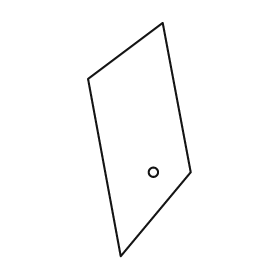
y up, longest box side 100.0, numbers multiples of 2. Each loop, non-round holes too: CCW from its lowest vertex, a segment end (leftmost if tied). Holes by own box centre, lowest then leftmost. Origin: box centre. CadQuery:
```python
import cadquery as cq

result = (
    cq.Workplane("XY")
    .moveTo(-8.0, -50.0)
    .lineTo(22.0, -14.0)
    .lineTo(10.0, 50.0)
    .lineTo(-22.0, 26.0)
    .close()
    .moveTo(6.0, -14.0)
    .circle(2.0)
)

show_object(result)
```